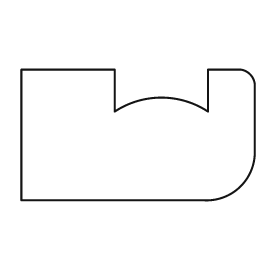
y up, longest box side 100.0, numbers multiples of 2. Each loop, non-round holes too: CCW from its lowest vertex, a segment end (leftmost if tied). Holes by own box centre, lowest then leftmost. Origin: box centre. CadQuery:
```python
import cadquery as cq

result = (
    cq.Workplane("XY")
    .moveTo(-50.0, -28.0)
    .lineTo(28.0, -28.0)
    .threePointArc((44.0, -22.0), (50.0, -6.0))
    .lineTo(50.0, 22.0)
    .threePointArc((48.0, 26.0), (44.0, 28.0))
    .lineTo(30.0, 28.0)
    .lineTo(30.0, 10.0)
    .threePointArc((10.0, 16.0), (-10.0, 10.0))
    .lineTo(-10.0, 28.0)
    .lineTo(-50.0, 28.0)
    .close()
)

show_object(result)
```